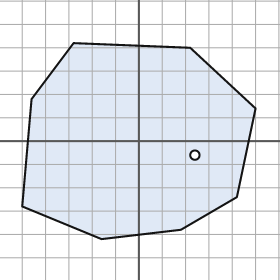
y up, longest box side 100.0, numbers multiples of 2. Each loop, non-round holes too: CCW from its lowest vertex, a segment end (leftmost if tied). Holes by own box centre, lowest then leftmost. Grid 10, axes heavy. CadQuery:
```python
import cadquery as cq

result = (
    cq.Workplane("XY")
    .moveTo(-16.0, -42.0)
    .lineTo(18.0, -38.0)
    .lineTo(42.0, -24.0)
    .lineTo(50.0, 14.0)
    .lineTo(22.0, 40.0)
    .lineTo(-28.0, 42.0)
    .lineTo(-46.0, 18.0)
    .lineTo(-50.0, -28.0)
    .close()
    .moveTo(24.0, -6.0)
    .circle(2.0)
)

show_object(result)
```